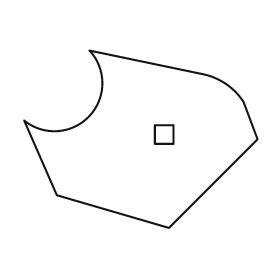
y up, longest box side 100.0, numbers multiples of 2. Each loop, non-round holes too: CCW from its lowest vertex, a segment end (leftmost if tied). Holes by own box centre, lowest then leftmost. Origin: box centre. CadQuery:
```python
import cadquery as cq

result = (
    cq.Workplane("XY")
    .moveTo(12.0, -38.0)
    .lineTo(50.0, 0.0)
    .lineTo(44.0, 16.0)
    .threePointArc((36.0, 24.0), (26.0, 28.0))
    .lineTo(-22.0, 38.0)
    .threePointArc((-22.0, 10.0), (-50.0, 8.0))
    .lineTo(-36.0, -24.0)
    .close()
    .moveTo(6.0, -2.0)
    .lineTo(14.0, -2.0)
    .lineTo(14.0, 6.0)
    .lineTo(6.0, 6.0)
    .close()
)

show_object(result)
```